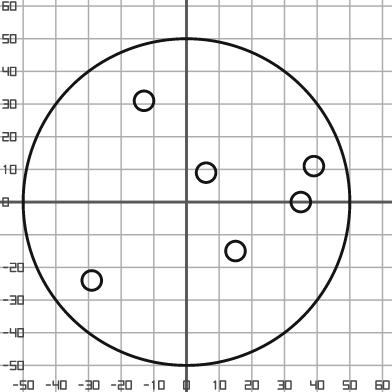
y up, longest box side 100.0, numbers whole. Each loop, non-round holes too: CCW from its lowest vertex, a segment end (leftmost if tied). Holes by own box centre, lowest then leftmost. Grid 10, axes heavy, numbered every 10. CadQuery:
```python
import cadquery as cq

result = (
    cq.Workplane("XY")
    .moveTo(0.0, 0.0)
    .circle(50.0)
    .moveTo(-29.0, -24.0)
    .circle(3.0)
    .moveTo(15.0, -15.0)
    .circle(3.0)
    .moveTo(35.0, 0.0)
    .circle(3.0)
    .moveTo(6.0, 9.0)
    .circle(3.0)
    .moveTo(39.0, 11.0)
    .circle(3.0)
    .moveTo(-13.0, 31.0)
    .circle(3.0)
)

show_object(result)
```